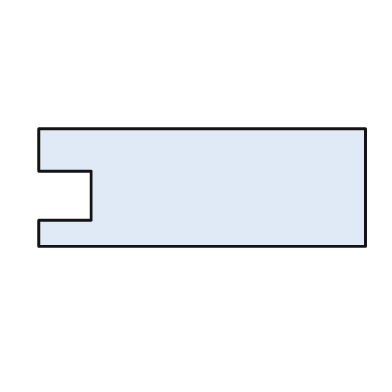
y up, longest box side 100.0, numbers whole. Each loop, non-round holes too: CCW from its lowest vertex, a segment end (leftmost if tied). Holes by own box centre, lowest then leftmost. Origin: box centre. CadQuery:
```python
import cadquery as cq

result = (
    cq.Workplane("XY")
    .moveTo(-50.0, -18.0)
    .lineTo(50.0, -18.0)
    .lineTo(50.0, 18.0)
    .lineTo(-50.0, 18.0)
    .lineTo(-50.0, 5.0)
    .lineTo(-34.0, 5.0)
    .lineTo(-34.0, -10.0)
    .lineTo(-50.0, -10.0)
    .close()
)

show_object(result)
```